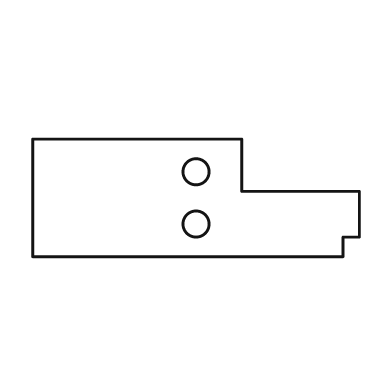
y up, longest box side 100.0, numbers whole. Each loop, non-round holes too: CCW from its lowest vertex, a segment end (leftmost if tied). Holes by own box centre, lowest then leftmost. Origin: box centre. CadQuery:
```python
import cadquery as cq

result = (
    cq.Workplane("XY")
    .moveTo(-50.0, -18.0)
    .lineTo(45.0, -18.0)
    .lineTo(45.0, -12.0)
    .lineTo(50.0, -12.0)
    .lineTo(50.0, 2.0)
    .lineTo(14.0, 2.0)
    .lineTo(14.0, 18.0)
    .lineTo(-50.0, 18.0)
    .close()
    .moveTo(0.0, -8.0)
    .circle(4.0)
    .moveTo(0.0, 8.0)
    .circle(4.0)
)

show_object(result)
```